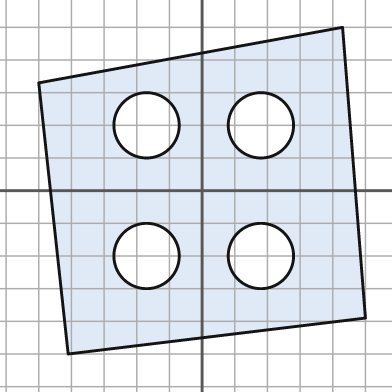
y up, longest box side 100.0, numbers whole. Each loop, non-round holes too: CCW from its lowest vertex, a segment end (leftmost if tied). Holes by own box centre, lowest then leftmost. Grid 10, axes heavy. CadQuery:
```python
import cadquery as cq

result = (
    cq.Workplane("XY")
    .moveTo(-41.0, -50.0)
    .lineTo(50.0, -39.0)
    .lineTo(43.0, 50.0)
    .lineTo(-50.0, 33.0)
    .close()
    .moveTo(-17.0, -20.0)
    .circle(10.0)
    .moveTo(18.0, -20.0)
    .circle(10.0)
    .moveTo(-17.0, 20.0)
    .circle(10.0)
    .moveTo(18.0, 20.0)
    .circle(10.0)
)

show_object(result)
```